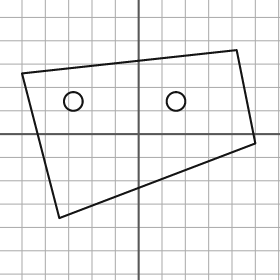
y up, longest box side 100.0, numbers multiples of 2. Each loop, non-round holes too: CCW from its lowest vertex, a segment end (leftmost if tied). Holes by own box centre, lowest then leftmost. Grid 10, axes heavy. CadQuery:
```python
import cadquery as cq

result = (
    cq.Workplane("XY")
    .moveTo(-34.0, -36.0)
    .lineTo(50.0, -4.0)
    .lineTo(42.0, 36.0)
    .lineTo(-50.0, 26.0)
    .close()
    .moveTo(-28.0, 14.0)
    .circle(4.0)
    .moveTo(16.0, 14.0)
    .circle(4.0)
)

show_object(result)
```